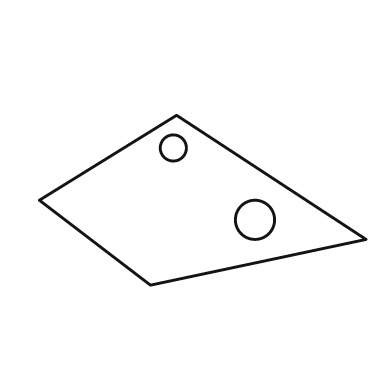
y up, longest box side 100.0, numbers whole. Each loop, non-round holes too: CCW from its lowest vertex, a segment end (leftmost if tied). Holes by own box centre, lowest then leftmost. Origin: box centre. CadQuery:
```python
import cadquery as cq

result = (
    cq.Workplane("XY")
    .moveTo(-16.0, -26.0)
    .lineTo(50.0, -12.0)
    .lineTo(-8.0, 26.0)
    .lineTo(-50.0, 0.0)
    .close()
    .moveTo(16.0, -6.0)
    .circle(6.0)
    .moveTo(-9.0, 16.0)
    .circle(4.0)
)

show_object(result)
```